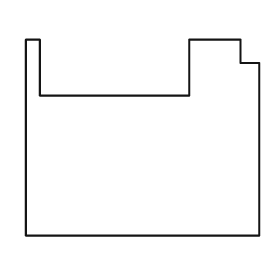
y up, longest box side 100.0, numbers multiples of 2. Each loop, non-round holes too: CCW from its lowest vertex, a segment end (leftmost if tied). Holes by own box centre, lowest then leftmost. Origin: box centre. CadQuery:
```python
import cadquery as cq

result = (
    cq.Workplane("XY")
    .moveTo(-50.0, -42.0)
    .lineTo(50.0, -42.0)
    .lineTo(50.0, 32.0)
    .lineTo(42.0, 32.0)
    .lineTo(42.0, 42.0)
    .lineTo(20.0, 42.0)
    .lineTo(20.0, 18.0)
    .lineTo(-44.0, 18.0)
    .lineTo(-44.0, 42.0)
    .lineTo(-50.0, 42.0)
    .close()
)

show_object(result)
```